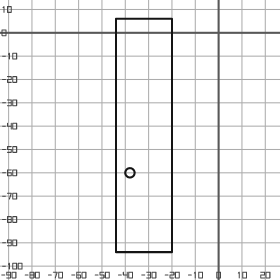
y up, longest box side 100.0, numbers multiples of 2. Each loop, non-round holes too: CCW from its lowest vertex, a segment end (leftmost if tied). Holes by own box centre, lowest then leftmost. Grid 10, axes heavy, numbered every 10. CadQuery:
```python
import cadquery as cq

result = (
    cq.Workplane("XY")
    .moveTo(-44.0, -94.0)
    .lineTo(-20.0, -94.0)
    .lineTo(-20.0, 6.0)
    .lineTo(-44.0, 6.0)
    .close()
    .moveTo(-38.0, -60.0)
    .circle(2.0)
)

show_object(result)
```